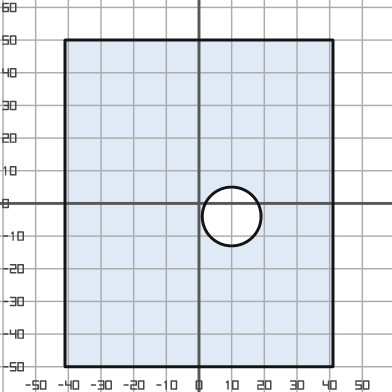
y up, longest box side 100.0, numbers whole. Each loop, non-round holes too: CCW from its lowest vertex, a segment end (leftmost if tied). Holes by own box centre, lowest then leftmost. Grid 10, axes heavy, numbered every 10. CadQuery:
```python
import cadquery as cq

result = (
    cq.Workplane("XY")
    .moveTo(-41.0, -50.0)
    .lineTo(41.0, -50.0)
    .lineTo(41.0, 50.0)
    .lineTo(-41.0, 50.0)
    .close()
    .moveTo(10.0, -4.0)
    .circle(9.0)
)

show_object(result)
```